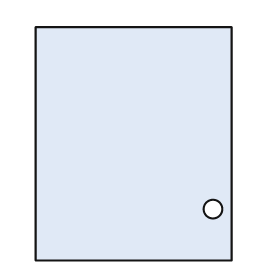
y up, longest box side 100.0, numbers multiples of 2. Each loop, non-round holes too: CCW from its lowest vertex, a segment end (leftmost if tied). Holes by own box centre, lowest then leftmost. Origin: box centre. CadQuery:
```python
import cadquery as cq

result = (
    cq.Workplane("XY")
    .moveTo(-42.0, -50.0)
    .lineTo(42.0, -50.0)
    .lineTo(42.0, 50.0)
    .lineTo(-42.0, 50.0)
    .close()
    .moveTo(34.0, -28.0)
    .circle(4.0)
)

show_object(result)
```